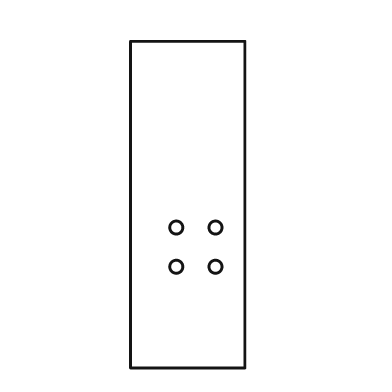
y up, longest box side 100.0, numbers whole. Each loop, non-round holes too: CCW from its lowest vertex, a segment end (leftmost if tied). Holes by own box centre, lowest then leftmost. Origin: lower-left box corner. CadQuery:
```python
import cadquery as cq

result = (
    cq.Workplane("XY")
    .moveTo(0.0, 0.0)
    .lineTo(35.0, 0.0)
    .lineTo(35.0, 100.0)
    .lineTo(0.0, 100.0)
    .close()
    .moveTo(14.0, 31.0)
    .circle(2.0)
    .moveTo(26.0, 31.0)
    .circle(2.0)
    .moveTo(14.0, 43.0)
    .circle(2.0)
    .moveTo(26.0, 43.0)
    .circle(2.0)
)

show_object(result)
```